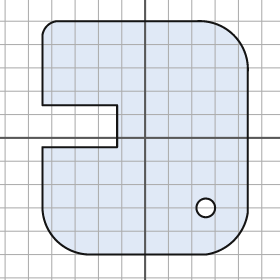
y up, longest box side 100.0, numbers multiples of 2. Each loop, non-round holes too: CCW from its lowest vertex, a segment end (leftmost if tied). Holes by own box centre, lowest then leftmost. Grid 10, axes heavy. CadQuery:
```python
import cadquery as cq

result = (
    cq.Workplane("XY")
    .moveTo(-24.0, -50.0)
    .lineTo(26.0, -50.0)
    .threePointArc((38.0, -44.0), (44.0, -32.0))
    .lineTo(44.0, 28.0)
    .threePointArc((38.0, 44.0), (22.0, 50.0))
    .lineTo(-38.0, 50.0)
    .threePointArc((-42.0, 48.0), (-44.0, 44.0))
    .lineTo(-44.0, 14.0)
    .lineTo(-12.0, 14.0)
    .lineTo(-12.0, -4.0)
    .lineTo(-44.0, -4.0)
    .lineTo(-44.0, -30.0)
    .threePointArc((-38.0, -44.0), (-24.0, -50.0))
    .close()
    .moveTo(26.0, -30.0)
    .circle(4.0)
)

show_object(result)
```